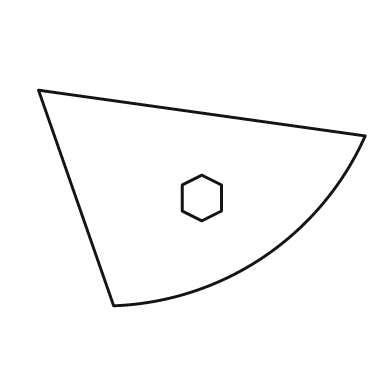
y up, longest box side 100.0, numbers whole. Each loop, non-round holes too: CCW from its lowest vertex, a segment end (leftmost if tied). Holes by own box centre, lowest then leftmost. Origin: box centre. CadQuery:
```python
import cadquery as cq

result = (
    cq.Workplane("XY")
    .moveTo(-27.0, -33.0)
    .threePointArc((19.0, -18.0), (50.0, 19.0))
    .lineTo(-50.0, 33.0)
    .close()
    .moveTo(0.0, -7.0)
    .lineTo(6.0, -4.0)
    .lineTo(6.0, 4.0)
    .lineTo(0.0, 7.0)
    .lineTo(-6.0, 4.0)
    .lineTo(-6.0, -4.0)
    .close()
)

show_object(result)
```